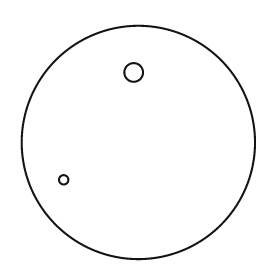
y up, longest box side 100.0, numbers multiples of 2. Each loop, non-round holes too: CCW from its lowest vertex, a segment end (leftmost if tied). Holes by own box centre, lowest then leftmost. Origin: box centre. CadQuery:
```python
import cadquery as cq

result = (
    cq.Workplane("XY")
    .moveTo(0.0, 0.0)
    .circle(50.0)
    .moveTo(-32.0, -16.0)
    .circle(2.0)
    .moveTo(-2.0, 30.0)
    .circle(4.0)
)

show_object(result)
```